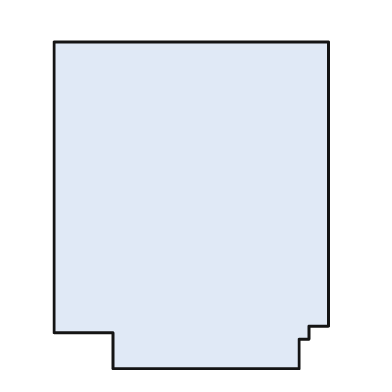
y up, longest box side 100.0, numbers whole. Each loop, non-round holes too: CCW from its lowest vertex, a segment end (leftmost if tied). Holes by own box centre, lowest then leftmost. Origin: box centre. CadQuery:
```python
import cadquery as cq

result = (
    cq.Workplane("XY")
    .moveTo(-24.0, -50.0)
    .lineTo(33.0, -50.0)
    .lineTo(33.0, -41.0)
    .lineTo(36.0, -41.0)
    .lineTo(36.0, -37.0)
    .lineTo(42.0, -37.0)
    .lineTo(42.0, 50.0)
    .lineTo(-42.0, 50.0)
    .lineTo(-42.0, -39.0)
    .lineTo(-24.0, -39.0)
    .close()
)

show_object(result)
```